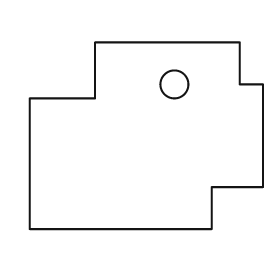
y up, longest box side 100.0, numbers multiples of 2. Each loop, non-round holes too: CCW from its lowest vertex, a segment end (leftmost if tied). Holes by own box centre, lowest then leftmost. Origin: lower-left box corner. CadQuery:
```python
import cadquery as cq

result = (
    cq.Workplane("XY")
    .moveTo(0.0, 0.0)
    .lineTo(78.0, 0.0)
    .lineTo(78.0, 18.0)
    .lineTo(100.0, 18.0)
    .lineTo(100.0, 62.0)
    .lineTo(90.0, 62.0)
    .lineTo(90.0, 80.0)
    .lineTo(28.0, 80.0)
    .lineTo(28.0, 56.0)
    .lineTo(0.0, 56.0)
    .close()
    .moveTo(62.0, 62.0)
    .circle(6.0)
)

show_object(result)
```